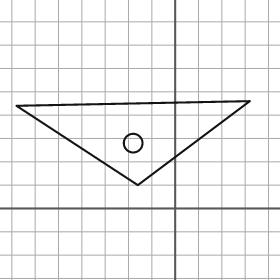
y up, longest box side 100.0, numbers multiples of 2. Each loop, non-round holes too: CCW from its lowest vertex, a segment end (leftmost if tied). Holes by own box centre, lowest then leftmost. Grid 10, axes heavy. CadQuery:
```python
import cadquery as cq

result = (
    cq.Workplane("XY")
    .moveTo(-16.0, 10.0)
    .lineTo(32.0, 46.0)
    .lineTo(-68.0, 44.0)
    .close()
    .moveTo(-18.0, 28.0)
    .circle(4.0)
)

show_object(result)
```